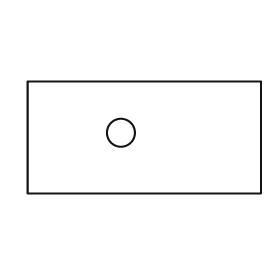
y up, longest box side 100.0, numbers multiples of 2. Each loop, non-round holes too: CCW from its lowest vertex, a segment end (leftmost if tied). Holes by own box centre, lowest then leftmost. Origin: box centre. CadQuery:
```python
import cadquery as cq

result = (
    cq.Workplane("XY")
    .moveTo(-50.0, -24.0)
    .lineTo(50.0, -24.0)
    .lineTo(50.0, 24.0)
    .lineTo(-50.0, 24.0)
    .close()
    .moveTo(-10.0, 2.0)
    .circle(6.0)
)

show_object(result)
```